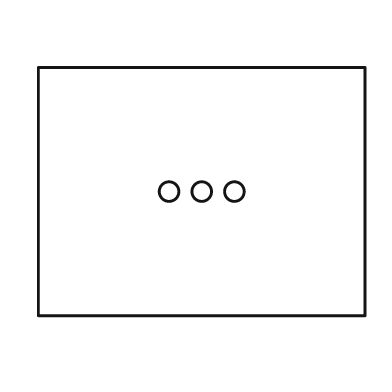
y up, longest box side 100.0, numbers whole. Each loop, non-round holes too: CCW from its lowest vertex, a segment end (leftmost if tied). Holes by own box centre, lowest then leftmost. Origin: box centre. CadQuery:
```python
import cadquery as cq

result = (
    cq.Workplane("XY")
    .moveTo(-50.0, -38.0)
    .lineTo(50.0, -38.0)
    .lineTo(50.0, 38.0)
    .lineTo(-50.0, 38.0)
    .close()
    .moveTo(-10.0, 0.0)
    .circle(3.0)
    .moveTo(0.0, 0.0)
    .circle(3.0)
    .moveTo(10.0, 0.0)
    .circle(3.0)
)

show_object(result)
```